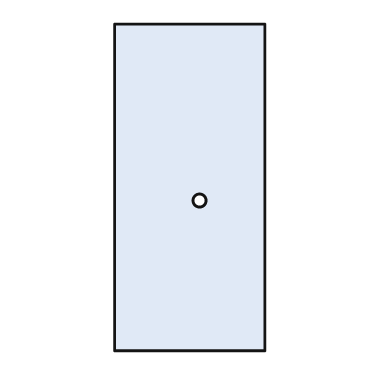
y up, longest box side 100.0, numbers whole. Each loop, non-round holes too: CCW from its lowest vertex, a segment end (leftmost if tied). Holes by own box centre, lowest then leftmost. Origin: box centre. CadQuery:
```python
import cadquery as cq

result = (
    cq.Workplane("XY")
    .moveTo(-23.0, -50.0)
    .lineTo(23.0, -50.0)
    .lineTo(23.0, 50.0)
    .lineTo(-23.0, 50.0)
    .close()
    .moveTo(3.0, -4.0)
    .circle(2.0)
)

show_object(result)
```